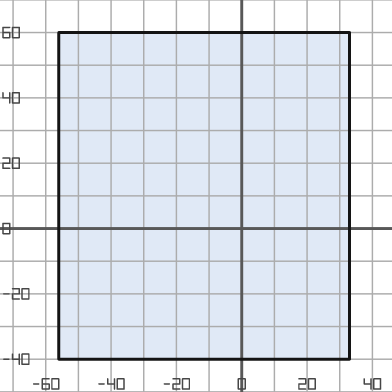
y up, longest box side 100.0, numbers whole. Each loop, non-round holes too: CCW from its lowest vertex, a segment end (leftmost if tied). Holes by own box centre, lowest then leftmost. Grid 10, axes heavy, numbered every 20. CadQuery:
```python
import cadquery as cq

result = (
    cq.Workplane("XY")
    .moveTo(-56.0, -40.0)
    .lineTo(33.0, -40.0)
    .lineTo(33.0, 60.0)
    .lineTo(-56.0, 60.0)
    .close()
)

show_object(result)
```